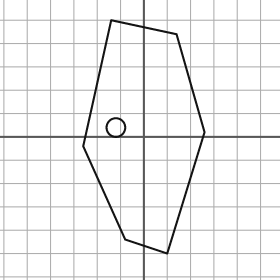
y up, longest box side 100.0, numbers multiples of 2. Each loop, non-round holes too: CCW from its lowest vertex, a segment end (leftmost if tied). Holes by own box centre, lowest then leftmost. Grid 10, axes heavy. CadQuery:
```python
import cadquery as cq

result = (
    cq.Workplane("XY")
    .moveTo(10.0, -50.0)
    .lineTo(26.0, 2.0)
    .lineTo(14.0, 44.0)
    .lineTo(-14.0, 50.0)
    .lineTo(-26.0, -4.0)
    .lineTo(-8.0, -44.0)
    .close()
    .moveTo(-12.0, 4.0)
    .circle(4.0)
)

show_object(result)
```